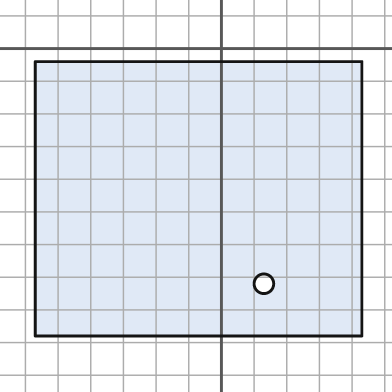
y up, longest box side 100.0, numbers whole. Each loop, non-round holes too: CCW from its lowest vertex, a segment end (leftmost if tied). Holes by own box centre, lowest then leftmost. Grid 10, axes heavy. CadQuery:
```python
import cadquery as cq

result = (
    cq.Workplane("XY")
    .moveTo(-57.0, -88.0)
    .lineTo(43.0, -88.0)
    .lineTo(43.0, -4.0)
    .lineTo(-57.0, -4.0)
    .close()
    .moveTo(13.0, -72.0)
    .circle(3.0)
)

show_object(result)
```